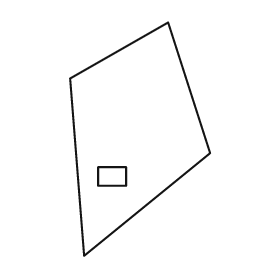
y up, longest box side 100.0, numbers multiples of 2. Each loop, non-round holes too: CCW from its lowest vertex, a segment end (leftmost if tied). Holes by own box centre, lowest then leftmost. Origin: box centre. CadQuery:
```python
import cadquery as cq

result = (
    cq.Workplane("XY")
    .moveTo(-24.0, -50.0)
    .lineTo(30.0, -6.0)
    .lineTo(12.0, 50.0)
    .lineTo(-30.0, 26.0)
    .close()
    .moveTo(-18.0, -20.0)
    .lineTo(-6.0, -20.0)
    .lineTo(-6.0, -12.0)
    .lineTo(-18.0, -12.0)
    .close()
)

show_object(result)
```